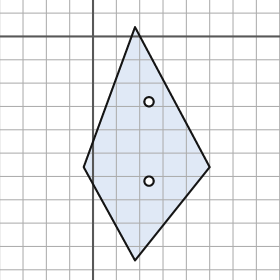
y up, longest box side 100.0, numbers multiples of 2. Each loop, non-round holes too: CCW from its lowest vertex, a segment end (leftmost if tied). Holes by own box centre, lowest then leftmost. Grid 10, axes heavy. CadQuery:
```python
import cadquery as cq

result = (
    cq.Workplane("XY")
    .moveTo(18.0, -96.0)
    .lineTo(50.0, -56.0)
    .lineTo(18.0, 4.0)
    .lineTo(-4.0, -56.0)
    .close()
    .moveTo(24.0, -62.0)
    .circle(2.0)
    .moveTo(24.0, -28.0)
    .circle(2.0)
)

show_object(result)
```